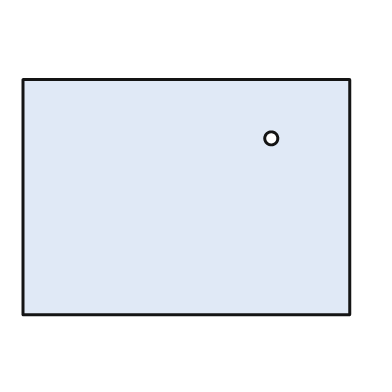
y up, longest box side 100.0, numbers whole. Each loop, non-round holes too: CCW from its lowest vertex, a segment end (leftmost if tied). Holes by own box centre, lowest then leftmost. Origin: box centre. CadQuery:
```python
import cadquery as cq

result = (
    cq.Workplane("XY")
    .moveTo(-50.0, -36.0)
    .lineTo(50.0, -36.0)
    .lineTo(50.0, 36.0)
    .lineTo(-50.0, 36.0)
    .close()
    .moveTo(26.0, 18.0)
    .circle(2.0)
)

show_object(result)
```